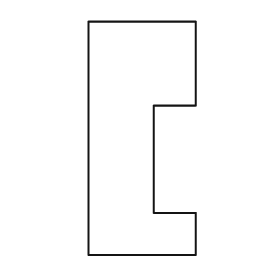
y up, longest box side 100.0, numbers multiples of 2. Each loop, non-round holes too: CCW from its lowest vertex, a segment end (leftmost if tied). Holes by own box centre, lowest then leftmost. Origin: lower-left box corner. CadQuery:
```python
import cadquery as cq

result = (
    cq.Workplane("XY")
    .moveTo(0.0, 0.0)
    .lineTo(46.0, 0.0)
    .lineTo(46.0, 18.0)
    .lineTo(28.0, 18.0)
    .lineTo(28.0, 64.0)
    .lineTo(46.0, 64.0)
    .lineTo(46.0, 100.0)
    .lineTo(0.0, 100.0)
    .close()
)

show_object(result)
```